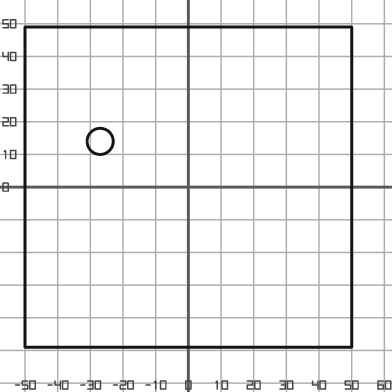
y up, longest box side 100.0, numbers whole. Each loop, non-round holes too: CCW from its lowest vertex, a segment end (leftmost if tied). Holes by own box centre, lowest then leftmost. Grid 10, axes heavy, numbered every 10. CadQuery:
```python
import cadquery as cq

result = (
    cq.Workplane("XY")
    .moveTo(-50.0, -49.0)
    .lineTo(50.0, -49.0)
    .lineTo(50.0, 49.0)
    .lineTo(-50.0, 49.0)
    .close()
    .moveTo(-27.0, 14.0)
    .circle(4.0)
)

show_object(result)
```